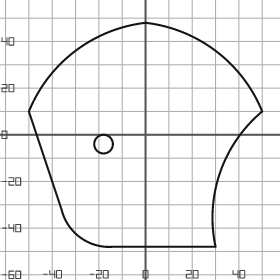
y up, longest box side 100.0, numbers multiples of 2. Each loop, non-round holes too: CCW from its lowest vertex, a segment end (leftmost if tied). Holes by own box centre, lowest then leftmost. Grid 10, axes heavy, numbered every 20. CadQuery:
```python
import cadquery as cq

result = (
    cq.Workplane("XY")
    .moveTo(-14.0, -48.0)
    .lineTo(30.0, -48.0)
    .threePointArc((32.0, -16.0), (50.0, 10.0))
    .threePointArc((30.0, 36.0), (0.0, 48.0))
    .threePointArc((-30.0, 36.0), (-50.0, 10.0))
    .lineTo(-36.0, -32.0)
    .threePointArc((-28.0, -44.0), (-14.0, -48.0))
    .close()
    .moveTo(-18.0, -4.0)
    .circle(4.0)
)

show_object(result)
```